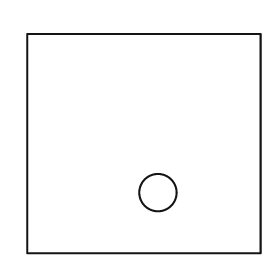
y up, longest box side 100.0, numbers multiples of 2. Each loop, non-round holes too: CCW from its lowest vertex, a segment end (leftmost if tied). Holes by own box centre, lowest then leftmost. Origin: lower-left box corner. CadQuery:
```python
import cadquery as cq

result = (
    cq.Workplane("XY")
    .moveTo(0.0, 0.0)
    .lineTo(100.0, 0.0)
    .lineTo(100.0, 94.0)
    .lineTo(0.0, 94.0)
    .close()
    .moveTo(56.0, 26.0)
    .circle(8.0)
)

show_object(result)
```